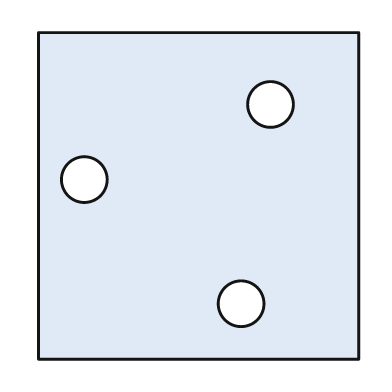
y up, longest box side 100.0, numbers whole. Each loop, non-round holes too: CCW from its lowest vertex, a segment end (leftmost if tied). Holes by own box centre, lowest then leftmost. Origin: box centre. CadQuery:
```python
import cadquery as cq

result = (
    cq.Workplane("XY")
    .moveTo(-49.0, -50.0)
    .lineTo(49.0, -50.0)
    .lineTo(49.0, 50.0)
    .lineTo(-49.0, 50.0)
    .close()
    .moveTo(13.0, -33.0)
    .circle(7.0)
    .moveTo(-35.0, 5.0)
    .circle(7.0)
    .moveTo(22.0, 28.0)
    .circle(7.0)
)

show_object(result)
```